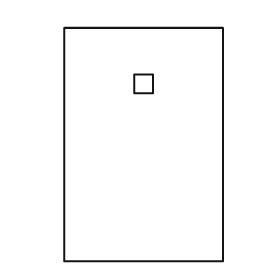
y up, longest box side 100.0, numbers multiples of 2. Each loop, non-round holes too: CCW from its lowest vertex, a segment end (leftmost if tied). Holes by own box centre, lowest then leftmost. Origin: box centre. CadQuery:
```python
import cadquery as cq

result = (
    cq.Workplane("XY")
    .moveTo(-34.0, -50.0)
    .lineTo(34.0, -50.0)
    .lineTo(34.0, 50.0)
    .lineTo(-34.0, 50.0)
    .close()
    .moveTo(-4.0, 22.0)
    .lineTo(4.0, 22.0)
    .lineTo(4.0, 30.0)
    .lineTo(-4.0, 30.0)
    .close()
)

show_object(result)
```